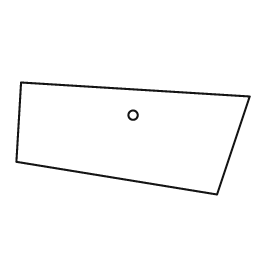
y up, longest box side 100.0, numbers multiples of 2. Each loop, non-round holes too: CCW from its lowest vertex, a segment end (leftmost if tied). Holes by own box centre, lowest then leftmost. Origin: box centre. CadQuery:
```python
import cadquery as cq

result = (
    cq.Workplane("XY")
    .moveTo(36.0, -24.0)
    .lineTo(50.0, 18.0)
    .lineTo(-48.0, 24.0)
    .lineTo(-50.0, -10.0)
    .close()
    .moveTo(0.0, 10.0)
    .circle(2.0)
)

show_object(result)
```